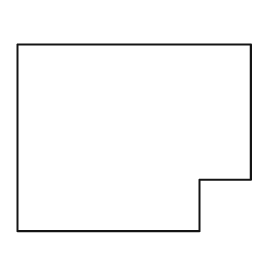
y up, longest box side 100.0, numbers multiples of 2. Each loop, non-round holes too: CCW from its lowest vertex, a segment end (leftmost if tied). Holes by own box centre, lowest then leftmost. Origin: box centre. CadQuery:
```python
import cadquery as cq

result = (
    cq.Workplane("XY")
    .moveTo(-50.0, -40.0)
    .lineTo(28.0, -40.0)
    .lineTo(28.0, -18.0)
    .lineTo(50.0, -18.0)
    .lineTo(50.0, 40.0)
    .lineTo(-50.0, 40.0)
    .close()
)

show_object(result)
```